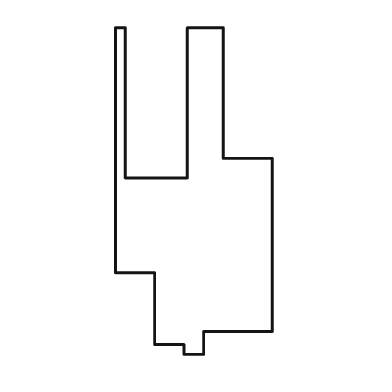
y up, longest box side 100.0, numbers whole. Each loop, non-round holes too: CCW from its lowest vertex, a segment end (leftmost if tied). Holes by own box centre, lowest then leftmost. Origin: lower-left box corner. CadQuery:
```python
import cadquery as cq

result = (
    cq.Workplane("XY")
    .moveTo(21.0, 0.0)
    .lineTo(27.0, 0.0)
    .lineTo(27.0, 7.0)
    .lineTo(48.0, 7.0)
    .lineTo(48.0, 60.0)
    .lineTo(33.0, 60.0)
    .lineTo(33.0, 100.0)
    .lineTo(22.0, 100.0)
    .lineTo(22.0, 54.0)
    .lineTo(3.0, 54.0)
    .lineTo(3.0, 100.0)
    .lineTo(0.0, 100.0)
    .lineTo(0.0, 25.0)
    .lineTo(12.0, 25.0)
    .lineTo(12.0, 3.0)
    .lineTo(21.0, 3.0)
    .close()
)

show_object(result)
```